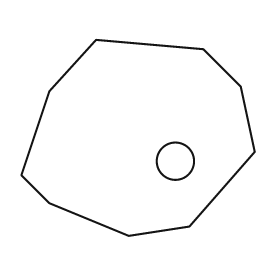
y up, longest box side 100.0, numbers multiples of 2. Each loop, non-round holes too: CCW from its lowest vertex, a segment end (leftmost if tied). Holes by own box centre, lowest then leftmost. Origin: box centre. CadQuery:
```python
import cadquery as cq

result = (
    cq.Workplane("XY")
    .moveTo(-4.0, -42.0)
    .lineTo(22.0, -38.0)
    .lineTo(50.0, -6.0)
    .lineTo(44.0, 22.0)
    .lineTo(28.0, 38.0)
    .lineTo(-18.0, 42.0)
    .lineTo(-38.0, 20.0)
    .lineTo(-50.0, -16.0)
    .lineTo(-38.0, -28.0)
    .close()
    .moveTo(16.0, -10.0)
    .circle(8.0)
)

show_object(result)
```